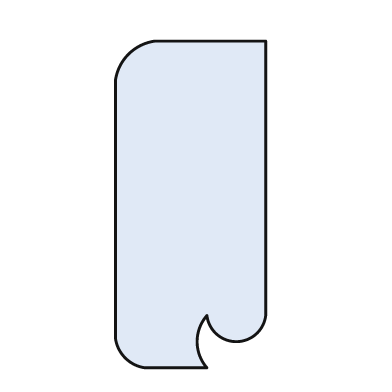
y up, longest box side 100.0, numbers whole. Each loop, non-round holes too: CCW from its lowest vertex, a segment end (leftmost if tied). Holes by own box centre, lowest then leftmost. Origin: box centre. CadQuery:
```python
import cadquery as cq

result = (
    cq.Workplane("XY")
    .moveTo(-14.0, -50.0)
    .lineTo(5.0, -50.0)
    .threePointArc((2.0, -42.0), (5.0, -34.0))
    .threePointArc((14.0, -42.0), (23.0, -34.0))
    .lineTo(23.0, 50.0)
    .lineTo(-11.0, 50.0)
    .threePointArc((-19.0, 46.0), (-23.0, 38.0))
    .lineTo(-23.0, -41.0)
    .threePointArc((-20.0, -47.0), (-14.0, -50.0))
    .close()
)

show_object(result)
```